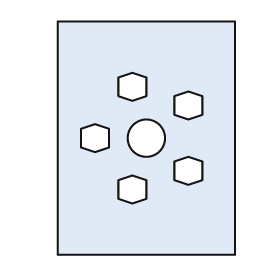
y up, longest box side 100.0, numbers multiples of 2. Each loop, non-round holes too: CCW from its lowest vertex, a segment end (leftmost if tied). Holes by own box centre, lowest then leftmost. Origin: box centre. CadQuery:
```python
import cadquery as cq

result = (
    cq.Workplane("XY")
    .moveTo(-38.0, -50.0)
    .lineTo(38.0, -50.0)
    .lineTo(38.0, 50.0)
    .lineTo(-38.0, 50.0)
    .close()
    .moveTo(-6.0, -28.0)
    .lineTo(0.0, -26.0)
    .lineTo(0.0, -18.0)
    .lineTo(-6.0, -16.0)
    .lineTo(-12.0, -18.0)
    .lineTo(-12.0, -26.0)
    .close()
    .moveTo(18.0, -20.0)
    .lineTo(24.0, -18.0)
    .lineTo(24.0, -10.0)
    .lineTo(18.0, -8.0)
    .lineTo(12.0, -10.0)
    .lineTo(12.0, -18.0)
    .close()
    .moveTo(-22.0, -6.0)
    .lineTo(-16.0, -4.0)
    .lineTo(-16.0, 4.0)
    .lineTo(-22.0, 6.0)
    .lineTo(-28.0, 4.0)
    .lineTo(-28.0, -4.0)
    .close()
    .moveTo(0.0, 0.0)
    .circle(8.0)
    .moveTo(18.0, 8.0)
    .lineTo(24.0, 10.0)
    .lineTo(24.0, 18.0)
    .lineTo(18.0, 20.0)
    .lineTo(12.0, 18.0)
    .lineTo(12.0, 10.0)
    .close()
    .moveTo(-6.0, 16.0)
    .lineTo(0.0, 18.0)
    .lineTo(0.0, 26.0)
    .lineTo(-6.0, 28.0)
    .lineTo(-12.0, 26.0)
    .lineTo(-12.0, 18.0)
    .close()
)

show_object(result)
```